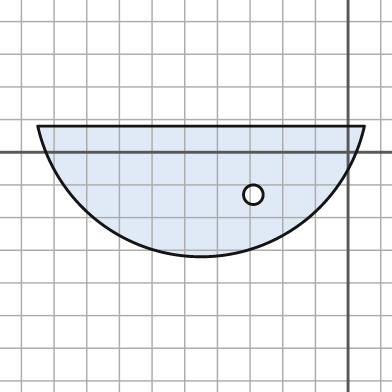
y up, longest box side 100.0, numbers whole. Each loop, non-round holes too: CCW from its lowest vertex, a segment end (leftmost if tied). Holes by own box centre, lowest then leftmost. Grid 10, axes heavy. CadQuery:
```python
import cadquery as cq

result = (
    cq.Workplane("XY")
    .moveTo(-95.0, 8.0)
    .threePointArc((-45.0, -32.0), (5.0, 8.0))
    .close()
    .moveTo(-29.0, -13.0)
    .circle(3.0)
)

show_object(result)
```